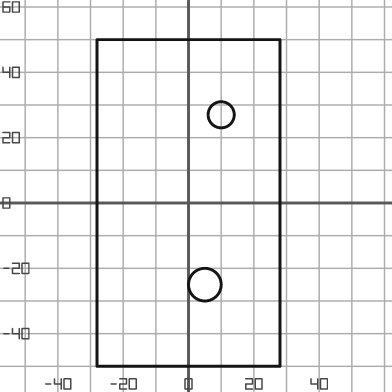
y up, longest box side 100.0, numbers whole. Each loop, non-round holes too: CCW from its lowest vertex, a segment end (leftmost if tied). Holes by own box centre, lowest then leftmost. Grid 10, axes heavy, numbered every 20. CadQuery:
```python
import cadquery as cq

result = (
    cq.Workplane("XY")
    .moveTo(-28.0, -50.0)
    .lineTo(28.0, -50.0)
    .lineTo(28.0, 50.0)
    .lineTo(-28.0, 50.0)
    .close()
    .moveTo(5.0, -25.0)
    .circle(5.0)
    .moveTo(10.0, 27.0)
    .circle(4.0)
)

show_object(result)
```